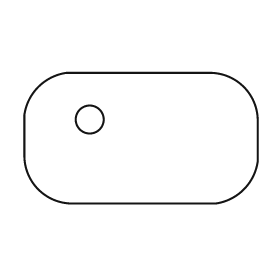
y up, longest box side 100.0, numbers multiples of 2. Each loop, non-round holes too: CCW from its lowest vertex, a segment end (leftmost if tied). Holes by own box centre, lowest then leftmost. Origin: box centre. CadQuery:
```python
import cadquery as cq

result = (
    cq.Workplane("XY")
    .moveTo(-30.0, -28.0)
    .lineTo(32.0, -28.0)
    .threePointArc((44.0, -22.0), (50.0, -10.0))
    .lineTo(50.0, 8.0)
    .threePointArc((44.0, 22.0), (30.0, 28.0))
    .lineTo(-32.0, 28.0)
    .threePointArc((-44.0, 22.0), (-50.0, 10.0))
    .lineTo(-50.0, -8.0)
    .threePointArc((-44.0, -22.0), (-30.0, -28.0))
    .close()
    .moveTo(-22.0, 8.0)
    .circle(6.0)
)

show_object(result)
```